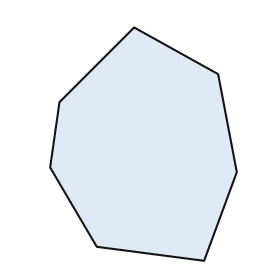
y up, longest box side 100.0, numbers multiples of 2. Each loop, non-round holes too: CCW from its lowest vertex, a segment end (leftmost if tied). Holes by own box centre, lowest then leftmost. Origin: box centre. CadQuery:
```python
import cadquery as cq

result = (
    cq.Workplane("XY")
    .moveTo(26.0, -50.0)
    .lineTo(40.0, -12.0)
    .lineTo(32.0, 30.0)
    .lineTo(-4.0, 50.0)
    .lineTo(-36.0, 18.0)
    .lineTo(-40.0, -10.0)
    .lineTo(-20.0, -44.0)
    .close()
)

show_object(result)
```